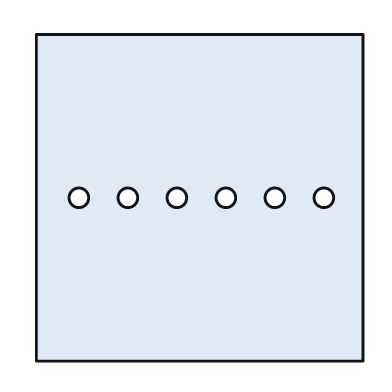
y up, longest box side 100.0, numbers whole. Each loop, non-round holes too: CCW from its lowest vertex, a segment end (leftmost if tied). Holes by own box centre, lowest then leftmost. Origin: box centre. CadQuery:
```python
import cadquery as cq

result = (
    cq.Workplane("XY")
    .moveTo(-50.0, -50.0)
    .lineTo(50.0, -50.0)
    .lineTo(50.0, 50.0)
    .lineTo(-50.0, 50.0)
    .close()
    .moveTo(-37.0, 0.0)
    .circle(3.0)
    .moveTo(-22.0, 0.0)
    .circle(3.0)
    .moveTo(-7.0, 0.0)
    .circle(3.0)
    .moveTo(8.0, 0.0)
    .circle(3.0)
    .moveTo(23.0, 0.0)
    .circle(3.0)
    .moveTo(38.0, 0.0)
    .circle(3.0)
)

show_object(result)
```